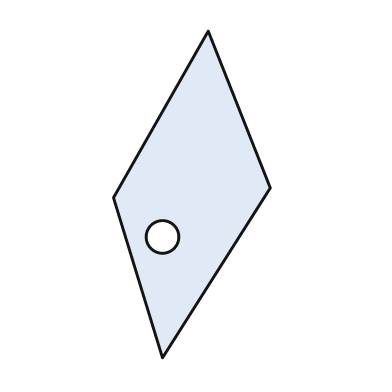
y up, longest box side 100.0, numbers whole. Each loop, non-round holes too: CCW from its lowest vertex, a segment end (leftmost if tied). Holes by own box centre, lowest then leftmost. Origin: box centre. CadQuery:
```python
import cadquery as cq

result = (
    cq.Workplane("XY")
    .moveTo(-9.0, -50.0)
    .lineTo(24.0, 2.0)
    .lineTo(5.0, 50.0)
    .lineTo(-24.0, -1.0)
    .close()
    .moveTo(-9.0, -13.0)
    .circle(5.0)
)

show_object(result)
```